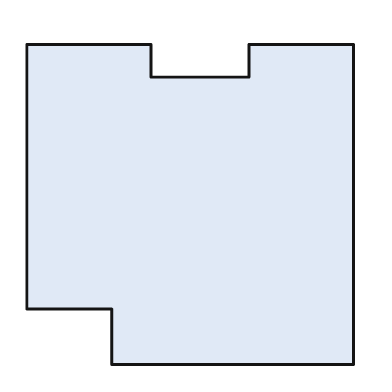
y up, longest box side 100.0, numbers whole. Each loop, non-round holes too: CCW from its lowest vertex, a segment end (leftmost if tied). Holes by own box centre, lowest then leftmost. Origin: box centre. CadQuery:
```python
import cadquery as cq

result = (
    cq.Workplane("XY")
    .moveTo(-24.0, -49.0)
    .lineTo(50.0, -49.0)
    .lineTo(50.0, 49.0)
    .lineTo(18.0, 49.0)
    .lineTo(18.0, 39.0)
    .lineTo(-12.0, 39.0)
    .lineTo(-12.0, 49.0)
    .lineTo(-50.0, 49.0)
    .lineTo(-50.0, -32.0)
    .lineTo(-24.0, -32.0)
    .close()
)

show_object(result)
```